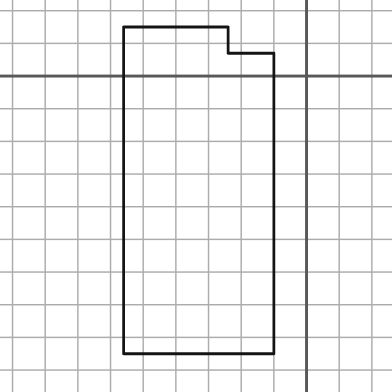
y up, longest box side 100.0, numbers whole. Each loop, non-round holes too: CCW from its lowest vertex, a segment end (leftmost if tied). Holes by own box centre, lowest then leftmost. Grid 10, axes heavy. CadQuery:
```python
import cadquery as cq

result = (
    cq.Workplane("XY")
    .moveTo(-56.0, -85.0)
    .lineTo(-10.0, -85.0)
    .lineTo(-10.0, 7.0)
    .lineTo(-24.0, 7.0)
    .lineTo(-24.0, 15.0)
    .lineTo(-56.0, 15.0)
    .close()
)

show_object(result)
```